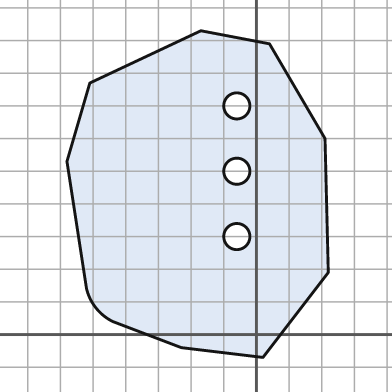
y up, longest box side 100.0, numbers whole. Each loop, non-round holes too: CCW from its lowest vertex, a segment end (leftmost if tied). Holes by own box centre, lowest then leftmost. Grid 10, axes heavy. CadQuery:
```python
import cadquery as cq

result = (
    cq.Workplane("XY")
    .moveTo(2.0, -7.0)
    .lineTo(22.0, 19.0)
    .lineTo(21.0, 60.0)
    .lineTo(4.0, 89.0)
    .lineTo(-17.0, 93.0)
    .lineTo(-51.0, 77.0)
    .lineTo(-58.0, 53.0)
    .lineTo(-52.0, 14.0)
    .threePointArc((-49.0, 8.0), (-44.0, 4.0))
    .lineTo(-23.0, -4.0)
    .close()
    .moveTo(-6.0, 30.0)
    .circle(4.0)
    .moveTo(-6.0, 50.0)
    .circle(4.0)
    .moveTo(-6.0, 70.0)
    .circle(4.0)
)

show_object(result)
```